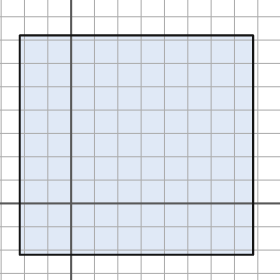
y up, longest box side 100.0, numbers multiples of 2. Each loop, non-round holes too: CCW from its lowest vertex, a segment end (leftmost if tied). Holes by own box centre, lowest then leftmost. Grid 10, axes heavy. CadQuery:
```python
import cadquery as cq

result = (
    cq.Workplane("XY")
    .moveTo(-22.0, -22.0)
    .lineTo(78.0, -22.0)
    .lineTo(78.0, 72.0)
    .lineTo(-22.0, 72.0)
    .close()
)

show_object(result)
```